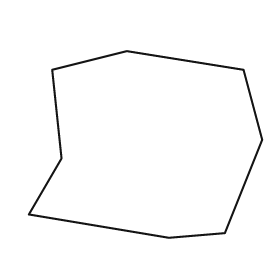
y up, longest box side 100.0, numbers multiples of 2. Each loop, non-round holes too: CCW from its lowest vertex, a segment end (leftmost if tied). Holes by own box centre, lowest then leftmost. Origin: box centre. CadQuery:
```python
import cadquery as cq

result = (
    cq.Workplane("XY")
    .moveTo(10.0, -40.0)
    .lineTo(34.0, -38.0)
    .lineTo(50.0, 2.0)
    .lineTo(42.0, 32.0)
    .lineTo(-8.0, 40.0)
    .lineTo(-40.0, 32.0)
    .lineTo(-36.0, -6.0)
    .lineTo(-50.0, -30.0)
    .close()
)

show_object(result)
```